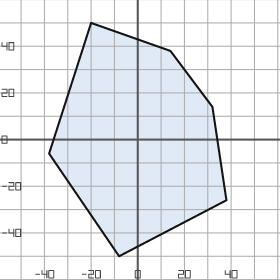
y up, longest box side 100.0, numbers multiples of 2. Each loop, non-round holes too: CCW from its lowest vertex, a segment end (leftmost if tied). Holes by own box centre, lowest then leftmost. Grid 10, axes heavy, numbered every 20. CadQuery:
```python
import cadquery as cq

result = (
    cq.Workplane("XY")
    .moveTo(-8.0, -50.0)
    .lineTo(38.0, -26.0)
    .lineTo(32.0, 14.0)
    .lineTo(14.0, 38.0)
    .lineTo(-20.0, 50.0)
    .lineTo(-38.0, -6.0)
    .close()
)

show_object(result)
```